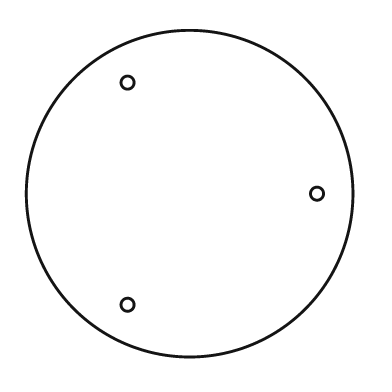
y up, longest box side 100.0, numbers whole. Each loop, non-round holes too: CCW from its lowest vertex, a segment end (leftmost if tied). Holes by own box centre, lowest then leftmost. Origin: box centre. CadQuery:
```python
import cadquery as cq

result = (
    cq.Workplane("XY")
    .moveTo(0.0, 0.0)
    .circle(50.0)
    .moveTo(-19.0, -34.0)
    .circle(2.0)
    .moveTo(39.0, 0.0)
    .circle(2.0)
    .moveTo(-19.0, 34.0)
    .circle(2.0)
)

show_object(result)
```